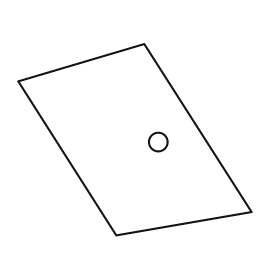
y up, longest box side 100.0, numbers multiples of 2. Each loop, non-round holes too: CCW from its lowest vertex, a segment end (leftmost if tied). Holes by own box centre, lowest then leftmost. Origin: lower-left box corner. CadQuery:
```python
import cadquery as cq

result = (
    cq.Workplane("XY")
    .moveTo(42.0, 0.0)
    .lineTo(100.0, 10.0)
    .lineTo(54.0, 82.0)
    .lineTo(0.0, 66.0)
    .close()
    .moveTo(60.0, 40.0)
    .circle(4.0)
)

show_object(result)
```